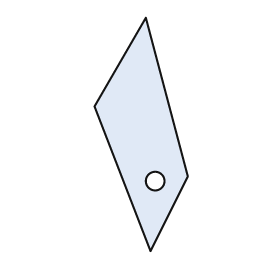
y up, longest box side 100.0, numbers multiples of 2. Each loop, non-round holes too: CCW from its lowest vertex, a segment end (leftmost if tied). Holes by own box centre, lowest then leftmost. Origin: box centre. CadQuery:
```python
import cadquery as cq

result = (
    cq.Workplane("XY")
    .moveTo(4.0, -50.0)
    .lineTo(20.0, -18.0)
    .lineTo(2.0, 50.0)
    .lineTo(-20.0, 12.0)
    .close()
    .moveTo(6.0, -20.0)
    .circle(4.0)
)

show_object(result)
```